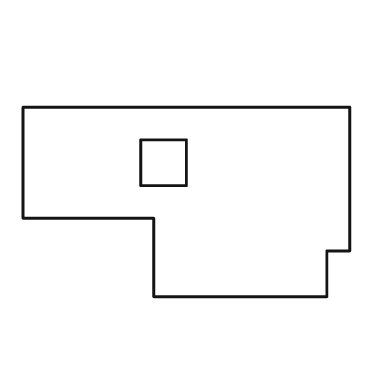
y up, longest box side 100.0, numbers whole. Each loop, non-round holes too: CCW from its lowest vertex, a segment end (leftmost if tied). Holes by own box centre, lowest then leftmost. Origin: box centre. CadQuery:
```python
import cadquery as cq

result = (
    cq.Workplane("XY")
    .moveTo(-10.0, -29.0)
    .lineTo(43.0, -29.0)
    .lineTo(43.0, -15.0)
    .lineTo(50.0, -15.0)
    .lineTo(50.0, 29.0)
    .lineTo(-50.0, 29.0)
    .lineTo(-50.0, -5.0)
    .lineTo(-10.0, -5.0)
    .close()
    .moveTo(-14.0, 5.0)
    .lineTo(0.0, 5.0)
    .lineTo(0.0, 19.0)
    .lineTo(-14.0, 19.0)
    .close()
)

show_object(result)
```